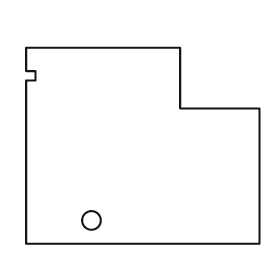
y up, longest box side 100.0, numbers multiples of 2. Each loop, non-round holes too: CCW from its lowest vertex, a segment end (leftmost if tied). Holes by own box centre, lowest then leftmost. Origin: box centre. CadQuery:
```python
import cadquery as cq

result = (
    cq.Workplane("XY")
    .moveTo(-50.0, -42.0)
    .lineTo(50.0, -42.0)
    .lineTo(50.0, 16.0)
    .lineTo(16.0, 16.0)
    .lineTo(16.0, 42.0)
    .lineTo(-50.0, 42.0)
    .lineTo(-50.0, 32.0)
    .lineTo(-46.0, 32.0)
    .lineTo(-46.0, 28.0)
    .lineTo(-50.0, 28.0)
    .close()
    .moveTo(-22.0, -32.0)
    .circle(4.0)
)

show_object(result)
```